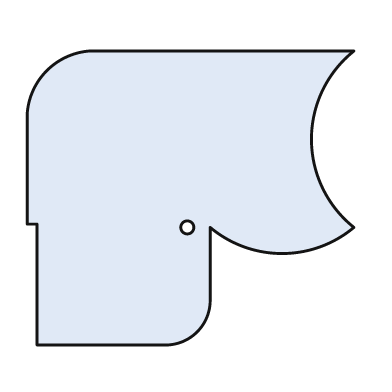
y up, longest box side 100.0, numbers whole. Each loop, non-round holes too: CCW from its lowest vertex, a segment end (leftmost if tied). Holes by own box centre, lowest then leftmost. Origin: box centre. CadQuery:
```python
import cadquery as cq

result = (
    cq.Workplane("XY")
    .moveTo(-47.0, -45.0)
    .lineTo(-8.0, -45.0)
    .threePointArc((2.0, -41.0), (6.0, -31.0))
    .lineTo(6.0, -9.0)
    .threePointArc((28.0, -17.0), (50.0, -9.0))
    .threePointArc((37.0, 18.0), (50.0, 45.0))
    .lineTo(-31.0, 45.0)
    .threePointArc((-44.0, 39.0), (-50.0, 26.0))
    .lineTo(-50.0, -8.0)
    .lineTo(-47.0, -8.0)
    .close()
    .moveTo(-1.0, -9.0)
    .circle(2.0)
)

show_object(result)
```